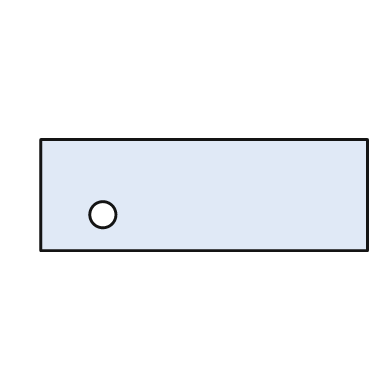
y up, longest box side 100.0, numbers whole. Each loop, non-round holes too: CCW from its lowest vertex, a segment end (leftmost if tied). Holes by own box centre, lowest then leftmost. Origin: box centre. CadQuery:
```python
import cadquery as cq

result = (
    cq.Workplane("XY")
    .moveTo(-50.0, -17.0)
    .lineTo(50.0, -17.0)
    .lineTo(50.0, 17.0)
    .lineTo(-50.0, 17.0)
    .close()
    .moveTo(-31.0, -6.0)
    .circle(4.0)
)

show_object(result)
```